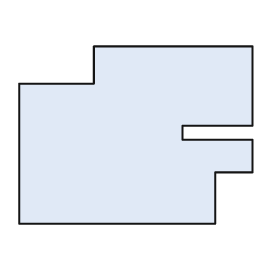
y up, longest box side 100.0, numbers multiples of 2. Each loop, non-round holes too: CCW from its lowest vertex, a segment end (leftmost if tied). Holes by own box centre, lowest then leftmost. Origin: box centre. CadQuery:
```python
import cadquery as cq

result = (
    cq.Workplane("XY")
    .moveTo(-50.0, -38.0)
    .lineTo(34.0, -38.0)
    .lineTo(34.0, -16.0)
    .lineTo(50.0, -16.0)
    .lineTo(50.0, -2.0)
    .lineTo(20.0, -2.0)
    .lineTo(20.0, 4.0)
    .lineTo(50.0, 4.0)
    .lineTo(50.0, 38.0)
    .lineTo(-18.0, 38.0)
    .lineTo(-18.0, 22.0)
    .lineTo(-50.0, 22.0)
    .close()
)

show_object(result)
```